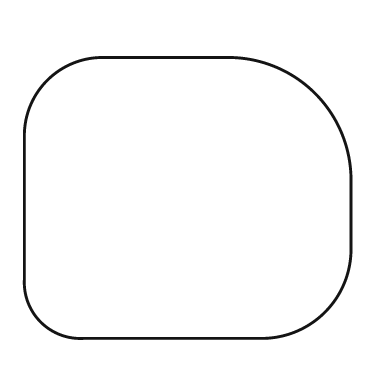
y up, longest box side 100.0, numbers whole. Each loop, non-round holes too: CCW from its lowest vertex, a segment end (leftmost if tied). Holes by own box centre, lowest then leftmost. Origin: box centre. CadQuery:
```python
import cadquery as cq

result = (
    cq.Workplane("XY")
    .moveTo(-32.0, -43.0)
    .lineTo(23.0, -43.0)
    .threePointArc((42.0, -35.0), (50.0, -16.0))
    .lineTo(50.0, 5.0)
    .threePointArc((39.0, 32.0), (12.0, 43.0))
    .lineTo(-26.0, 43.0)
    .threePointArc((-43.0, 36.0), (-50.0, 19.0))
    .lineTo(-50.0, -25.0)
    .threePointArc((-45.0, -38.0), (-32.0, -43.0))
    .close()
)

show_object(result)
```